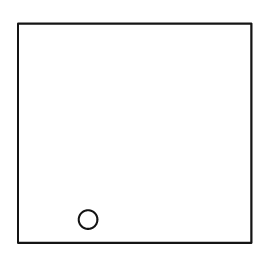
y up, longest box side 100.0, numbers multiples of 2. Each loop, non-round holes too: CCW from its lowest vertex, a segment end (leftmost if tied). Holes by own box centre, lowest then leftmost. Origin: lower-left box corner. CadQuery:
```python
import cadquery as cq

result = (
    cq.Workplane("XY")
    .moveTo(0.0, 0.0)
    .lineTo(100.0, 0.0)
    .lineTo(100.0, 94.0)
    .lineTo(0.0, 94.0)
    .close()
    .moveTo(30.0, 10.0)
    .circle(4.0)
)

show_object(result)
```